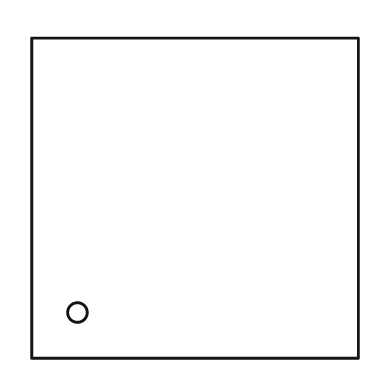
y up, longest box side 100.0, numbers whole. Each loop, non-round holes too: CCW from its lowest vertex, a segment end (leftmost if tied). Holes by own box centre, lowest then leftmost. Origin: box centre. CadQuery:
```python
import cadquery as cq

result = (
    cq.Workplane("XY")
    .moveTo(-50.0, -49.0)
    .lineTo(50.0, -49.0)
    .lineTo(50.0, 49.0)
    .lineTo(-50.0, 49.0)
    .close()
    .moveTo(-36.0, -35.0)
    .circle(3.0)
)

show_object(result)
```